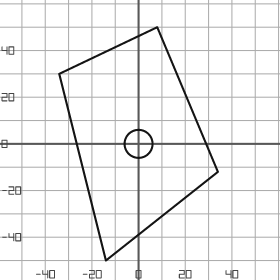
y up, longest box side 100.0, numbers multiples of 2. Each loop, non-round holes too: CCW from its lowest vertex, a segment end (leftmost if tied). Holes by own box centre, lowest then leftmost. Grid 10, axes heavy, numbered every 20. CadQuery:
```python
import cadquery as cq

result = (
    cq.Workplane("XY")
    .moveTo(-14.0, -50.0)
    .lineTo(34.0, -12.0)
    .lineTo(8.0, 50.0)
    .lineTo(-34.0, 30.0)
    .close()
    .moveTo(0.0, 0.0)
    .circle(6.0)
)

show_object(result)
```